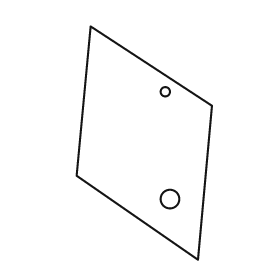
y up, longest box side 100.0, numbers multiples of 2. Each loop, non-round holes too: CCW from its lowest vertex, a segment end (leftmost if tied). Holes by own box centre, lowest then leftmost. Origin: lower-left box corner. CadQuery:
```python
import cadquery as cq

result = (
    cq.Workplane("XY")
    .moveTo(52.0, 0.0)
    .lineTo(58.0, 66.0)
    .lineTo(6.0, 100.0)
    .lineTo(0.0, 36.0)
    .close()
    .moveTo(40.0, 26.0)
    .circle(4.0)
    .moveTo(38.0, 72.0)
    .circle(2.0)
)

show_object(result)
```